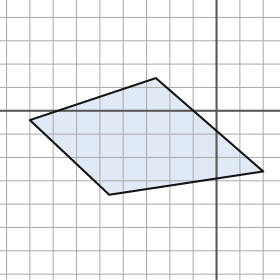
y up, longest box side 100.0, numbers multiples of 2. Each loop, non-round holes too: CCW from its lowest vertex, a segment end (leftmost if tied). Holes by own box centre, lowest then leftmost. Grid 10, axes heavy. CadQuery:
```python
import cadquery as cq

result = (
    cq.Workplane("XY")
    .moveTo(-46.0, -36.0)
    .lineTo(20.0, -26.0)
    .lineTo(-26.0, 14.0)
    .lineTo(-80.0, -4.0)
    .close()
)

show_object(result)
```